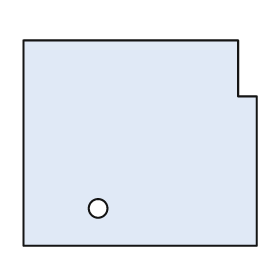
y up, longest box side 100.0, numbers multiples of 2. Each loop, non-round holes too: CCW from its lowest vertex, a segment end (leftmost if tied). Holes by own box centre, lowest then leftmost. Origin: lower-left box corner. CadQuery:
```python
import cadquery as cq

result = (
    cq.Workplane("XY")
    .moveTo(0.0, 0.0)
    .lineTo(100.0, 0.0)
    .lineTo(100.0, 64.0)
    .lineTo(92.0, 64.0)
    .lineTo(92.0, 88.0)
    .lineTo(0.0, 88.0)
    .close()
    .moveTo(32.0, 16.0)
    .circle(4.0)
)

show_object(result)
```